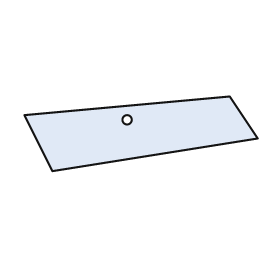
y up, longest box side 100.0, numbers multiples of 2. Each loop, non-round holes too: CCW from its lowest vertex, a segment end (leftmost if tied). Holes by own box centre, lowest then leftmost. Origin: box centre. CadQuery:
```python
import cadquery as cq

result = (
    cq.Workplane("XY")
    .moveTo(-38.0, -16.0)
    .lineTo(50.0, -2.0)
    .lineTo(38.0, 16.0)
    .lineTo(-50.0, 8.0)
    .close()
    .moveTo(-6.0, 6.0)
    .circle(2.0)
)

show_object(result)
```